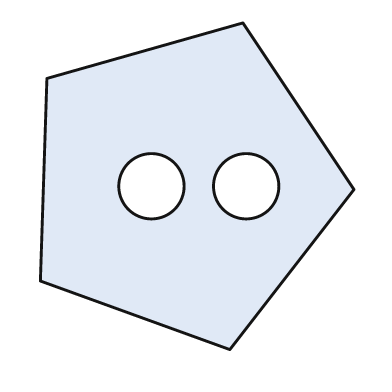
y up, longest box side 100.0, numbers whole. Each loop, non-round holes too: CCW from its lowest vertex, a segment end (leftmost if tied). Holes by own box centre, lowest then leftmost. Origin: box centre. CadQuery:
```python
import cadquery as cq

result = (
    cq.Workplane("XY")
    .moveTo(10.0, -50.0)
    .lineTo(48.0, -1.0)
    .lineTo(14.0, 50.0)
    .lineTo(-46.0, 33.0)
    .lineTo(-48.0, -29.0)
    .close()
    .moveTo(-14.0, 0.0)
    .circle(10.0)
    .moveTo(15.0, 0.0)
    .circle(10.0)
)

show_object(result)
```